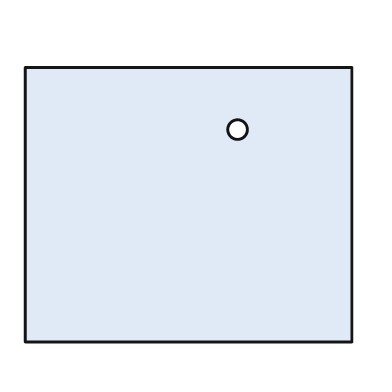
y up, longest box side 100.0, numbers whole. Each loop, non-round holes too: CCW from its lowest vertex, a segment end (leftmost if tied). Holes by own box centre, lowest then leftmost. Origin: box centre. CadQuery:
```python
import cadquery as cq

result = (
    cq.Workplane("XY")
    .moveTo(-50.0, -42.0)
    .lineTo(50.0, -42.0)
    .lineTo(50.0, 42.0)
    .lineTo(-50.0, 42.0)
    .close()
    .moveTo(15.0, 23.0)
    .circle(3.0)
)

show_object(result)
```